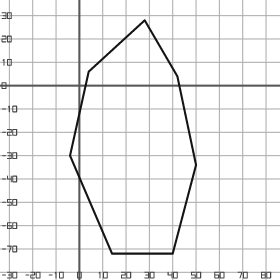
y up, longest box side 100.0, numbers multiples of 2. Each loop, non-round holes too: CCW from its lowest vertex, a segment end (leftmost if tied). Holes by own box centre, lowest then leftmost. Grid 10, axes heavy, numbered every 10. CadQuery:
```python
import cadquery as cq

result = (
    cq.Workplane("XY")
    .moveTo(14.0, -72.0)
    .lineTo(40.0, -72.0)
    .lineTo(50.0, -34.0)
    .lineTo(42.0, 4.0)
    .lineTo(28.0, 28.0)
    .lineTo(4.0, 6.0)
    .lineTo(-4.0, -30.0)
    .close()
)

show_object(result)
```